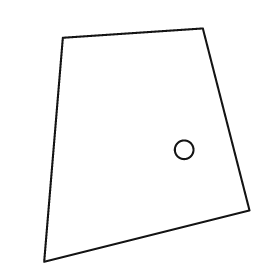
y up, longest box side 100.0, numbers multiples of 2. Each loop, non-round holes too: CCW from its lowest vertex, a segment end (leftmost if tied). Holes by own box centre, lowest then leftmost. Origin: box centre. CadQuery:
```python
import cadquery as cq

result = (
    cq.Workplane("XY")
    .moveTo(-44.0, -50.0)
    .lineTo(44.0, -28.0)
    .lineTo(24.0, 50.0)
    .lineTo(-36.0, 46.0)
    .close()
    .moveTo(16.0, -2.0)
    .circle(4.0)
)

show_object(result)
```